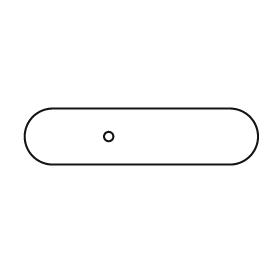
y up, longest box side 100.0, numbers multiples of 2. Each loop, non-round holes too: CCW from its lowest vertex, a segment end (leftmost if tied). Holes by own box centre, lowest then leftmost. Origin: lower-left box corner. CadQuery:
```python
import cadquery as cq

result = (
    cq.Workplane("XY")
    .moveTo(12.0, 0.0)
    .lineTo(88.0, 0.0)
    .threePointArc((100.0, 12.0), (88.0, 24.0))
    .lineTo(12.0, 24.0)
    .threePointArc((0.0, 12.0), (12.0, 0.0))
    .close()
    .moveTo(36.0, 12.0)
    .circle(2.0)
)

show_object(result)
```